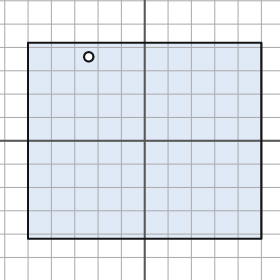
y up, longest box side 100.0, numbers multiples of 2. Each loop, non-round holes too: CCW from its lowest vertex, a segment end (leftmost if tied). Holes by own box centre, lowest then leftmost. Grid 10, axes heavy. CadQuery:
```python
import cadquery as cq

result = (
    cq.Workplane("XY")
    .moveTo(-50.0, -42.0)
    .lineTo(50.0, -42.0)
    .lineTo(50.0, 42.0)
    .lineTo(-50.0, 42.0)
    .close()
    .moveTo(-24.0, 36.0)
    .circle(2.0)
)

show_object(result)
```